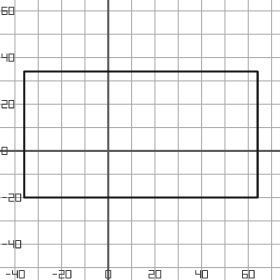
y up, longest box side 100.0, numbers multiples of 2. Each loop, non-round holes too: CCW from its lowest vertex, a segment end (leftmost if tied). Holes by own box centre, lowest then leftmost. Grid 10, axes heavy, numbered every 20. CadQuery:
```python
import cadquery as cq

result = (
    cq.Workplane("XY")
    .moveTo(-36.0, -20.0)
    .lineTo(64.0, -20.0)
    .lineTo(64.0, 34.0)
    .lineTo(-36.0, 34.0)
    .close()
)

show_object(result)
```